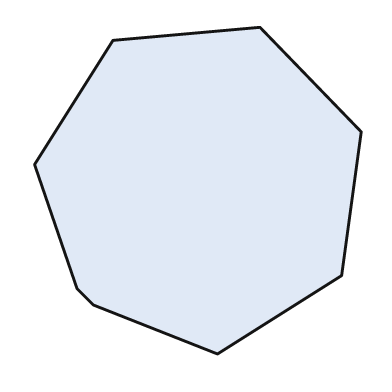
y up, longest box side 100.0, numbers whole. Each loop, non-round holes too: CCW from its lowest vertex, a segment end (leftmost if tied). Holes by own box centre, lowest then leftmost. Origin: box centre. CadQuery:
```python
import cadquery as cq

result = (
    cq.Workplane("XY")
    .moveTo(6.0, -50.0)
    .lineTo(44.0, -26.0)
    .lineTo(50.0, 18.0)
    .lineTo(19.0, 50.0)
    .lineTo(-26.0, 46.0)
    .lineTo(-50.0, 8.0)
    .lineTo(-37.0, -30.0)
    .lineTo(-32.0, -35.0)
    .close()
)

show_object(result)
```